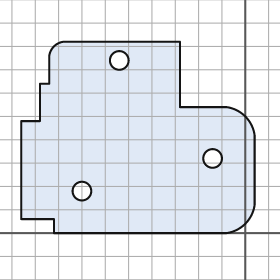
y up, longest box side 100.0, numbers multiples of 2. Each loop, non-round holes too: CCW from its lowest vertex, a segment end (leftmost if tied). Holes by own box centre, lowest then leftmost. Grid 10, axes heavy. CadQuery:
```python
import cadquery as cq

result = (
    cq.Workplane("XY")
    .moveTo(-82.0, 0.0)
    .lineTo(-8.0, 0.0)
    .threePointArc((0.0, 4.0), (4.0, 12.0))
    .lineTo(4.0, 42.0)
    .threePointArc((0.0, 50.0), (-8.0, 54.0))
    .lineTo(-28.0, 54.0)
    .lineTo(-28.0, 82.0)
    .lineTo(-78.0, 82.0)
    .threePointArc((-82.0, 80.0), (-84.0, 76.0))
    .lineTo(-84.0, 64.0)
    .lineTo(-88.0, 64.0)
    .lineTo(-88.0, 48.0)
    .lineTo(-96.0, 48.0)
    .lineTo(-96.0, 6.0)
    .lineTo(-82.0, 6.0)
    .close()
    .moveTo(-70.0, 18.0)
    .circle(4.0)
    .moveTo(-14.0, 32.0)
    .circle(4.0)
    .moveTo(-54.0, 74.0)
    .circle(4.0)
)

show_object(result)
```